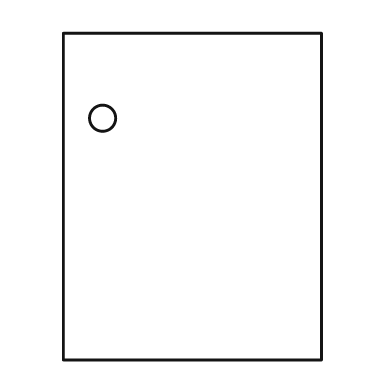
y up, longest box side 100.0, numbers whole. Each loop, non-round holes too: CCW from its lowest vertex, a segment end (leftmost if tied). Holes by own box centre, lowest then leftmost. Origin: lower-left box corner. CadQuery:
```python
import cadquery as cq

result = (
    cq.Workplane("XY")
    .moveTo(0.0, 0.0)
    .lineTo(79.0, 0.0)
    .lineTo(79.0, 100.0)
    .lineTo(0.0, 100.0)
    .close()
    .moveTo(12.0, 74.0)
    .circle(4.0)
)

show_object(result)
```